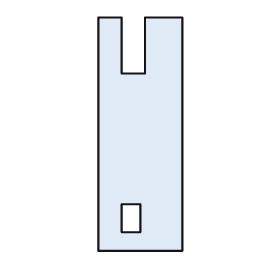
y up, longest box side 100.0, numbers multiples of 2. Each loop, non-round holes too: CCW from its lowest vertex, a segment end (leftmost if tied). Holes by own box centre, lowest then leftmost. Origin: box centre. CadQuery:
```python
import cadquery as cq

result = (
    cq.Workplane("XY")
    .moveTo(-18.0, -50.0)
    .lineTo(18.0, -50.0)
    .lineTo(18.0, 50.0)
    .lineTo(2.0, 50.0)
    .lineTo(2.0, 26.0)
    .lineTo(-8.0, 26.0)
    .lineTo(-8.0, 50.0)
    .lineTo(-18.0, 50.0)
    .close()
    .moveTo(-8.0, -42.0)
    .lineTo(0.0, -42.0)
    .lineTo(0.0, -30.0)
    .lineTo(-8.0, -30.0)
    .close()
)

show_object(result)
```